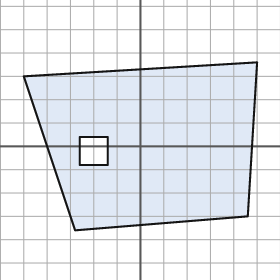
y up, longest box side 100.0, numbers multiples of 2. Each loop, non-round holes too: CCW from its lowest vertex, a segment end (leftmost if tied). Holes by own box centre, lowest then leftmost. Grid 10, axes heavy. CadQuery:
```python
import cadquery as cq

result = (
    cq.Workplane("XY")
    .moveTo(-28.0, -36.0)
    .lineTo(46.0, -30.0)
    .lineTo(50.0, 36.0)
    .lineTo(-50.0, 30.0)
    .close()
    .moveTo(-26.0, -8.0)
    .lineTo(-14.0, -8.0)
    .lineTo(-14.0, 4.0)
    .lineTo(-26.0, 4.0)
    .close()
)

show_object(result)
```